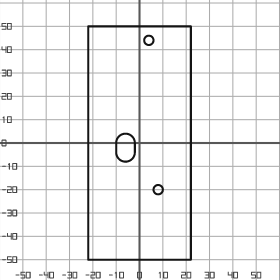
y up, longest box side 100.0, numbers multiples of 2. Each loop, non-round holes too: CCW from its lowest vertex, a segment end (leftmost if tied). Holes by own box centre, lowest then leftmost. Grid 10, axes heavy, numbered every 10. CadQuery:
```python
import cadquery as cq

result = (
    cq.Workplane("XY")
    .moveTo(-22.0, -50.0)
    .lineTo(22.0, -50.0)
    .lineTo(22.0, 50.0)
    .lineTo(-22.0, 50.0)
    .close()
    .moveTo(8.0, -20.0)
    .circle(2.0)
    .moveTo(-10.0, -4.0)
    .threePointArc((-6.0, -8.0), (-2.0, -4.0))
    .lineTo(-2.0, 0.0)
    .threePointArc((-6.0, 4.0), (-10.0, 0.0))
    .close()
    .moveTo(4.0, 44.0)
    .circle(2.0)
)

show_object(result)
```